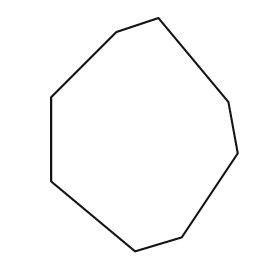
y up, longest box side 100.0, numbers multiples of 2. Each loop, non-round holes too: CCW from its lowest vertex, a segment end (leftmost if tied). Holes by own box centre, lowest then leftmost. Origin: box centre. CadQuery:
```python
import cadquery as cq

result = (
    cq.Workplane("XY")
    .moveTo(-4.0, -50.0)
    .lineTo(16.0, -44.0)
    .lineTo(40.0, -8.0)
    .lineTo(36.0, 14.0)
    .lineTo(6.0, 50.0)
    .lineTo(-12.0, 44.0)
    .lineTo(-40.0, 16.0)
    .lineTo(-40.0, -20.0)
    .close()
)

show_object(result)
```